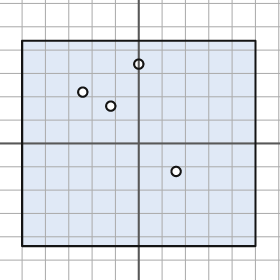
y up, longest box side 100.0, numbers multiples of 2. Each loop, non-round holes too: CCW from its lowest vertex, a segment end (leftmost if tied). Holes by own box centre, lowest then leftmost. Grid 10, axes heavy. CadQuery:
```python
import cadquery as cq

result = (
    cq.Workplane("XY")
    .moveTo(-50.0, -44.0)
    .lineTo(50.0, -44.0)
    .lineTo(50.0, 44.0)
    .lineTo(-50.0, 44.0)
    .close()
    .moveTo(16.0, -12.0)
    .circle(2.0)
    .moveTo(-12.0, 16.0)
    .circle(2.0)
    .moveTo(-24.0, 22.0)
    .circle(2.0)
    .moveTo(0.0, 34.0)
    .circle(2.0)
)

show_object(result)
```